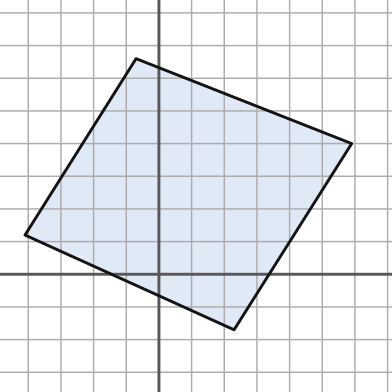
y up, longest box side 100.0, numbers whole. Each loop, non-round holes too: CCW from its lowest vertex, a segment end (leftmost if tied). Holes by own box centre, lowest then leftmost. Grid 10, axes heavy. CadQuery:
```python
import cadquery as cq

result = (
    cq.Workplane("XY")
    .moveTo(23.0, -17.0)
    .lineTo(59.0, 40.0)
    .lineTo(-7.0, 66.0)
    .lineTo(-41.0, 12.0)
    .close()
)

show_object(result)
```